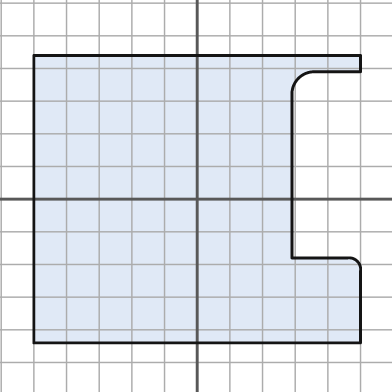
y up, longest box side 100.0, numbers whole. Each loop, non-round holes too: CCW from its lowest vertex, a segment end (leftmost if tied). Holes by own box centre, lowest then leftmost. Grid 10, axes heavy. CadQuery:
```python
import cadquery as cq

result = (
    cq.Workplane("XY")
    .moveTo(-50.0, -44.0)
    .lineTo(50.0, -44.0)
    .lineTo(50.0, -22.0)
    .threePointArc((49.0, -19.0), (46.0, -18.0))
    .lineTo(29.0, -18.0)
    .lineTo(29.0, 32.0)
    .threePointArc((31.0, 37.0), (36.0, 39.0))
    .lineTo(50.0, 39.0)
    .lineTo(50.0, 44.0)
    .lineTo(-50.0, 44.0)
    .close()
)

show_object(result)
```